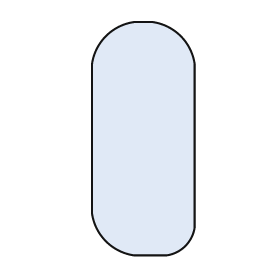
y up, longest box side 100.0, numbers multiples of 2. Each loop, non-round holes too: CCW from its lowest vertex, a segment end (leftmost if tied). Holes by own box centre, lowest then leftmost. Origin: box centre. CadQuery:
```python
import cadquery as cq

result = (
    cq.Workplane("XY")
    .moveTo(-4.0, -50.0)
    .lineTo(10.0, -50.0)
    .threePointArc((18.0, -46.0), (22.0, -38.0))
    .lineTo(22.0, 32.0)
    .threePointArc((16.0, 44.0), (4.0, 50.0))
    .lineTo(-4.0, 50.0)
    .threePointArc((-16.0, 44.0), (-22.0, 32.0))
    .lineTo(-22.0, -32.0)
    .threePointArc((-16.0, -44.0), (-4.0, -50.0))
    .close()
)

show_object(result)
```